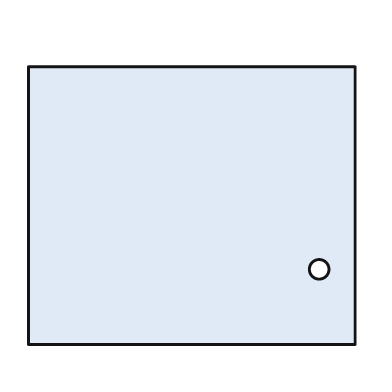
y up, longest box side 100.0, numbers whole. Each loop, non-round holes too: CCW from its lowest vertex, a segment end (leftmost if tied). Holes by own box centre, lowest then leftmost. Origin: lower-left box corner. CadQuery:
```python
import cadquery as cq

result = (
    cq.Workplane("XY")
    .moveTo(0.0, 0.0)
    .lineTo(100.0, 0.0)
    .lineTo(100.0, 85.0)
    .lineTo(0.0, 85.0)
    .close()
    .moveTo(89.0, 23.0)
    .circle(3.0)
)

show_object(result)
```